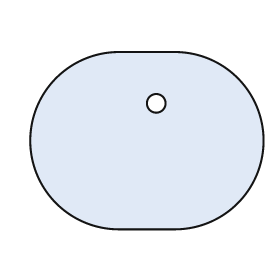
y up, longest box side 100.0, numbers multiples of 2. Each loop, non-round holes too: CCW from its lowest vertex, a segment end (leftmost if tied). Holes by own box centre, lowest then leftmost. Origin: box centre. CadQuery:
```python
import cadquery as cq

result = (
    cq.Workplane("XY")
    .moveTo(-12.0, -38.0)
    .lineTo(12.0, -38.0)
    .threePointArc((50.0, 0.0), (12.0, 38.0))
    .lineTo(-12.0, 38.0)
    .threePointArc((-50.0, 0.0), (-12.0, -38.0))
    .close()
    .moveTo(4.0, 16.0)
    .circle(4.0)
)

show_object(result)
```